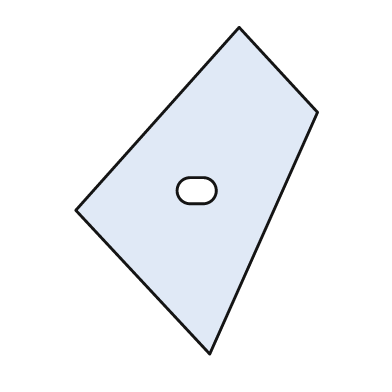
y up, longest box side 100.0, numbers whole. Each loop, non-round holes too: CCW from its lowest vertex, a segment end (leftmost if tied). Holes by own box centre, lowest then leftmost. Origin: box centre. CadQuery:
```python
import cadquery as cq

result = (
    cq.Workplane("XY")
    .moveTo(4.0, -50.0)
    .lineTo(37.0, 24.0)
    .lineTo(13.0, 50.0)
    .lineTo(-37.0, -6.0)
    .close()
    .moveTo(-2.0, -4.0)
    .lineTo(2.0, -4.0)
    .threePointArc((6.0, 0.0), (2.0, 4.0))
    .lineTo(-2.0, 4.0)
    .threePointArc((-6.0, 0.0), (-2.0, -4.0))
    .close()
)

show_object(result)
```